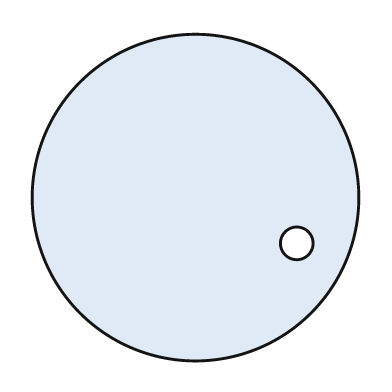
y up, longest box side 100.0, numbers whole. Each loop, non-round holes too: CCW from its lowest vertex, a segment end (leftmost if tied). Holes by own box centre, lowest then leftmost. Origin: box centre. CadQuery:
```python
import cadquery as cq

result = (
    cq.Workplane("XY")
    .moveTo(0.0, 0.0)
    .circle(50.0)
    .moveTo(31.0, -14.0)
    .circle(5.0)
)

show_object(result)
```